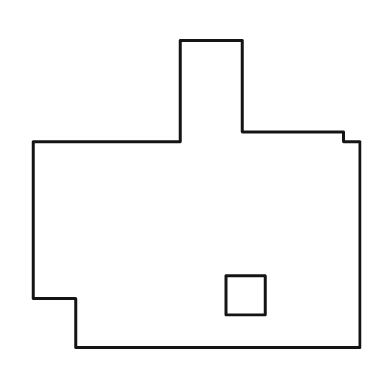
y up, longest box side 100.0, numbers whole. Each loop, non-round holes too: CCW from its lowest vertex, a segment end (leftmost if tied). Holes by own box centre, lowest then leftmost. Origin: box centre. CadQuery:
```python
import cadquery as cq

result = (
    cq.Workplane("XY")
    .moveTo(-37.0, -47.0)
    .lineTo(50.0, -47.0)
    .lineTo(50.0, 16.0)
    .lineTo(45.0, 16.0)
    .lineTo(45.0, 19.0)
    .lineTo(14.0, 19.0)
    .lineTo(14.0, 47.0)
    .lineTo(-5.0, 47.0)
    .lineTo(-5.0, 16.0)
    .lineTo(-50.0, 16.0)
    .lineTo(-50.0, -32.0)
    .lineTo(-37.0, -32.0)
    .close()
    .moveTo(9.0, -37.0)
    .lineTo(21.0, -37.0)
    .lineTo(21.0, -25.0)
    .lineTo(9.0, -25.0)
    .close()
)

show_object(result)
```